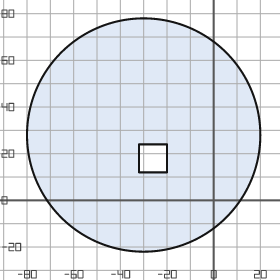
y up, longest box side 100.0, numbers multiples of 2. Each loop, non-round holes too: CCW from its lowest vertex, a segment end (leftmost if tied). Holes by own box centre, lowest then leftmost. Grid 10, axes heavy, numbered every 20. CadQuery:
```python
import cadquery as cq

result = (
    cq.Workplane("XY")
    .moveTo(-30.0, 28.0)
    .circle(50.0)
    .moveTo(-32.0, 12.0)
    .lineTo(-20.0, 12.0)
    .lineTo(-20.0, 24.0)
    .lineTo(-32.0, 24.0)
    .close()
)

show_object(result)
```